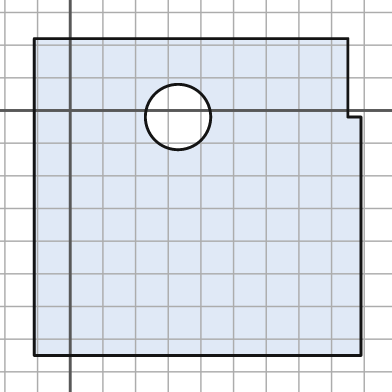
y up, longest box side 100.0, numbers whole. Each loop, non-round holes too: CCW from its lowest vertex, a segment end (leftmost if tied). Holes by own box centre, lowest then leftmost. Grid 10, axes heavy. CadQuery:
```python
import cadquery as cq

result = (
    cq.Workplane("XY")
    .moveTo(-11.0, -75.0)
    .lineTo(89.0, -75.0)
    .lineTo(89.0, -2.0)
    .lineTo(85.0, -2.0)
    .lineTo(85.0, 22.0)
    .lineTo(-11.0, 22.0)
    .close()
    .moveTo(33.0, -2.0)
    .circle(10.0)
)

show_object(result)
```